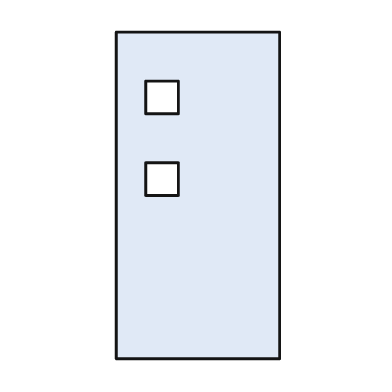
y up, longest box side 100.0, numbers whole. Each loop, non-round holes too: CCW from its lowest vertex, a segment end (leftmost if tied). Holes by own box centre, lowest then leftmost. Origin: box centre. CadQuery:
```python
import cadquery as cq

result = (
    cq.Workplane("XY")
    .moveTo(-25.0, -50.0)
    .lineTo(25.0, -50.0)
    .lineTo(25.0, 50.0)
    .lineTo(-25.0, 50.0)
    .close()
    .moveTo(-16.0, 0.0)
    .lineTo(-6.0, 0.0)
    .lineTo(-6.0, 10.0)
    .lineTo(-16.0, 10.0)
    .close()
    .moveTo(-16.0, 25.0)
    .lineTo(-6.0, 25.0)
    .lineTo(-6.0, 35.0)
    .lineTo(-16.0, 35.0)
    .close()
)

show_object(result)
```